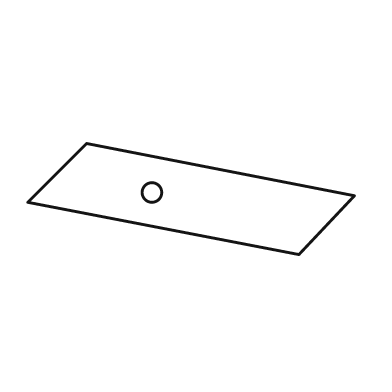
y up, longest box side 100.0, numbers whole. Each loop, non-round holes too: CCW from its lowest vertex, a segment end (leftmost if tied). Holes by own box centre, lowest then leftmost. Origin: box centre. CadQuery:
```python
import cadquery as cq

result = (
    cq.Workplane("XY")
    .moveTo(33.0, -17.0)
    .lineTo(50.0, 1.0)
    .lineTo(-32.0, 17.0)
    .lineTo(-50.0, -1.0)
    .close()
    .moveTo(-12.0, 2.0)
    .circle(3.0)
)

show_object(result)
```